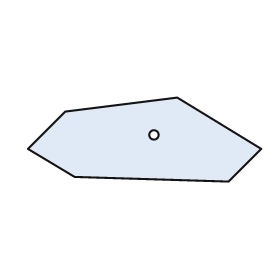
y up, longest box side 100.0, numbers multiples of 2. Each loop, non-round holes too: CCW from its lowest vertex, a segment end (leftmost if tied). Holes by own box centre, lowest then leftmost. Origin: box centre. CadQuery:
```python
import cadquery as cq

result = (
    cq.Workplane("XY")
    .moveTo(36.0, -18.0)
    .lineTo(50.0, -4.0)
    .lineTo(14.0, 18.0)
    .lineTo(-34.0, 12.0)
    .lineTo(-50.0, -4.0)
    .lineTo(-30.0, -16.0)
    .close()
    .moveTo(4.0, 2.0)
    .circle(2.0)
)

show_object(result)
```